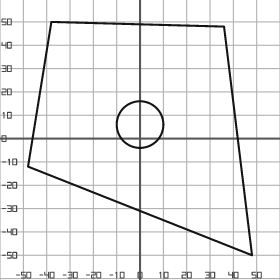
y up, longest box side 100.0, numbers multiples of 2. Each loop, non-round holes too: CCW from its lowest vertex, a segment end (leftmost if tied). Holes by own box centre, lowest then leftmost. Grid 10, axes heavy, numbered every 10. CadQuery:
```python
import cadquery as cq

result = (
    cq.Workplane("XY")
    .moveTo(48.0, -50.0)
    .lineTo(36.0, 48.0)
    .lineTo(-38.0, 50.0)
    .lineTo(-48.0, -12.0)
    .close()
    .moveTo(0.0, 6.0)
    .circle(10.0)
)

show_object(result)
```